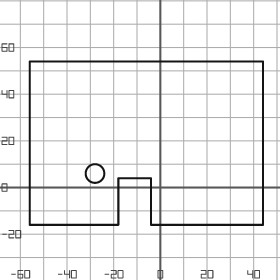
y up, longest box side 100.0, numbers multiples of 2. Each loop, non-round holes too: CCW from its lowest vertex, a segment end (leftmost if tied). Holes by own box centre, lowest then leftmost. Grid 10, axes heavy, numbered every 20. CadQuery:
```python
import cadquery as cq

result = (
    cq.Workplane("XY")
    .moveTo(-56.0, -16.0)
    .lineTo(-18.0, -16.0)
    .lineTo(-18.0, 4.0)
    .lineTo(-4.0, 4.0)
    .lineTo(-4.0, -16.0)
    .lineTo(44.0, -16.0)
    .lineTo(44.0, 54.0)
    .lineTo(-56.0, 54.0)
    .close()
    .moveTo(-28.0, 6.0)
    .circle(4.0)
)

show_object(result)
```